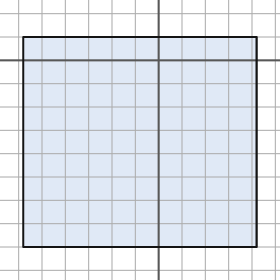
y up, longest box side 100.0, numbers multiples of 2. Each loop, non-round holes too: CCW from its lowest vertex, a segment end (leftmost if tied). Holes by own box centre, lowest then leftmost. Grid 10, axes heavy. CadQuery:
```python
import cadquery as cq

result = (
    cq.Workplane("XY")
    .moveTo(-58.0, -80.0)
    .lineTo(42.0, -80.0)
    .lineTo(42.0, 10.0)
    .lineTo(-58.0, 10.0)
    .close()
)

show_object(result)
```